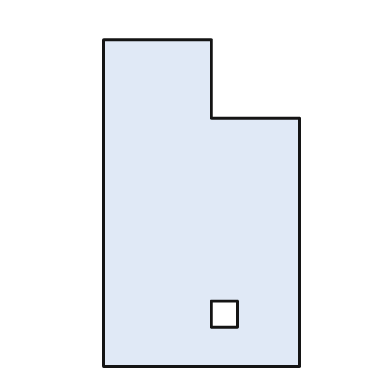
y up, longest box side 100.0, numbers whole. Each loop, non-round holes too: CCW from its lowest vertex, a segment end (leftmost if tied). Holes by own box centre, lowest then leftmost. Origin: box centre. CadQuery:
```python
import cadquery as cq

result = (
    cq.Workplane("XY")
    .moveTo(-30.0, -50.0)
    .lineTo(30.0, -50.0)
    .lineTo(30.0, 26.0)
    .lineTo(3.0, 26.0)
    .lineTo(3.0, 50.0)
    .lineTo(-30.0, 50.0)
    .close()
    .moveTo(3.0, -38.0)
    .lineTo(11.0, -38.0)
    .lineTo(11.0, -30.0)
    .lineTo(3.0, -30.0)
    .close()
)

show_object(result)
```